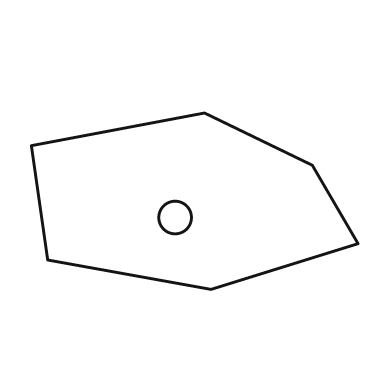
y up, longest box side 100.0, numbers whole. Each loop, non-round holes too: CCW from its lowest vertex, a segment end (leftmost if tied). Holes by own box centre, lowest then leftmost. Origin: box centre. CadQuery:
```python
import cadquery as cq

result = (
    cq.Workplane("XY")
    .moveTo(5.0, -27.0)
    .lineTo(50.0, -13.0)
    .lineTo(36.0, 11.0)
    .lineTo(3.0, 27.0)
    .lineTo(-50.0, 17.0)
    .lineTo(-45.0, -18.0)
    .close()
    .moveTo(-6.0, -5.0)
    .circle(5.0)
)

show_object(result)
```